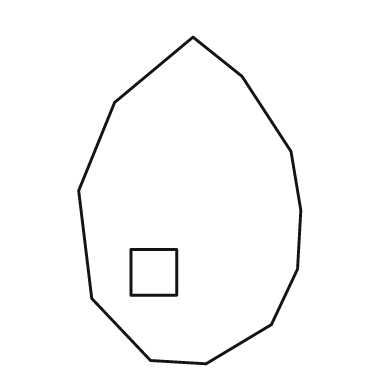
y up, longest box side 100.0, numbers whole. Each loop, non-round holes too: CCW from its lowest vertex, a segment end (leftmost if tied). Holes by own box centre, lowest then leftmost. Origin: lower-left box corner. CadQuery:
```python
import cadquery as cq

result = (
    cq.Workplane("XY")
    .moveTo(39.0, 0.0)
    .lineTo(59.0, 12.0)
    .lineTo(67.0, 29.0)
    .lineTo(68.0, 47.0)
    .lineTo(65.0, 65.0)
    .lineTo(50.0, 88.0)
    .lineTo(35.0, 100.0)
    .lineTo(11.0, 80.0)
    .lineTo(0.0, 53.0)
    .lineTo(4.0, 20.0)
    .lineTo(22.0, 1.0)
    .close()
    .moveTo(16.0, 21.0)
    .lineTo(30.0, 21.0)
    .lineTo(30.0, 35.0)
    .lineTo(16.0, 35.0)
    .close()
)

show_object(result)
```